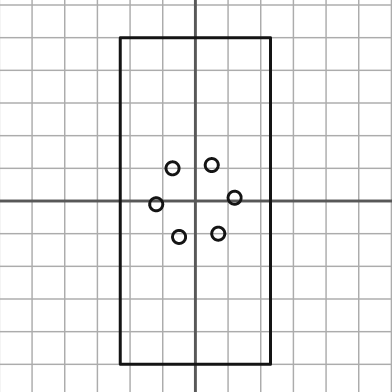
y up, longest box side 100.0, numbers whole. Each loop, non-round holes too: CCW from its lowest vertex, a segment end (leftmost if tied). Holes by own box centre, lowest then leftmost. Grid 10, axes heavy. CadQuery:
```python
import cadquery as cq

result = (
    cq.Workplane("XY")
    .moveTo(-23.0, -50.0)
    .lineTo(23.0, -50.0)
    .lineTo(23.0, 50.0)
    .lineTo(-23.0, 50.0)
    .close()
    .moveTo(-5.0, -11.0)
    .circle(2.0)
    .moveTo(7.0, -10.0)
    .circle(2.0)
    .moveTo(-12.0, -1.0)
    .circle(2.0)
    .moveTo(12.0, 1.0)
    .circle(2.0)
    .moveTo(-7.0, 10.0)
    .circle(2.0)
    .moveTo(5.0, 11.0)
    .circle(2.0)
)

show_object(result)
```